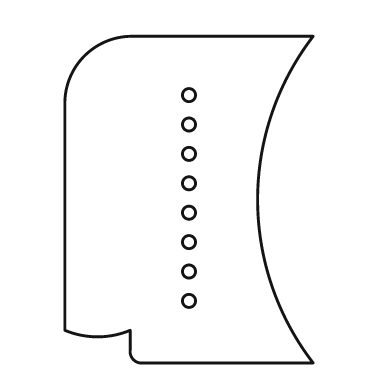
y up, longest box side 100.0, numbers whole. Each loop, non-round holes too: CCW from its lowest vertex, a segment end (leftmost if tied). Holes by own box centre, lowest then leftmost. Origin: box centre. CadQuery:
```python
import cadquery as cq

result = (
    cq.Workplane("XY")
    .moveTo(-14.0, -50.0)
    .lineTo(38.0, -50.0)
    .threePointArc((21.0, 0.0), (38.0, 50.0))
    .lineTo(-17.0, 50.0)
    .threePointArc((-32.0, 44.0), (-38.0, 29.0))
    .lineTo(-38.0, -40.0)
    .threePointArc((-28.0, -42.0), (-18.0, -40.0))
    .lineTo(-18.0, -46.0)
    .threePointArc((-17.0, -49.0), (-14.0, -50.0))
    .close()
    .moveTo(0.0, -31.0)
    .circle(2.0)
    .moveTo(0.0, -22.0)
    .circle(2.0)
    .moveTo(0.0, -13.0)
    .circle(2.0)
    .moveTo(0.0, -4.0)
    .circle(2.0)
    .moveTo(0.0, 5.0)
    .circle(2.0)
    .moveTo(0.0, 14.0)
    .circle(2.0)
    .moveTo(0.0, 23.0)
    .circle(2.0)
    .moveTo(0.0, 32.0)
    .circle(2.0)
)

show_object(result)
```